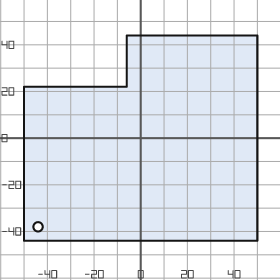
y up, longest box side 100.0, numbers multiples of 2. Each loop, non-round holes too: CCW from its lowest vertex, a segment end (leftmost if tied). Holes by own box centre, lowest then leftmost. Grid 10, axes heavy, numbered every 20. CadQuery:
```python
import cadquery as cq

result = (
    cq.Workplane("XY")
    .moveTo(-50.0, -44.0)
    .lineTo(50.0, -44.0)
    .lineTo(50.0, 44.0)
    .lineTo(-6.0, 44.0)
    .lineTo(-6.0, 22.0)
    .lineTo(-50.0, 22.0)
    .close()
    .moveTo(-44.0, -38.0)
    .circle(2.0)
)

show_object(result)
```